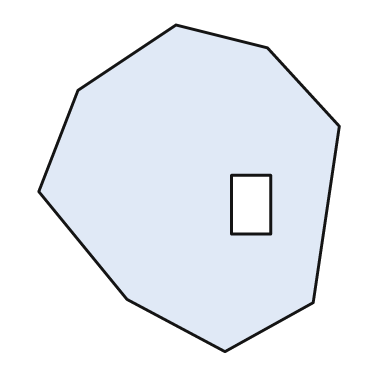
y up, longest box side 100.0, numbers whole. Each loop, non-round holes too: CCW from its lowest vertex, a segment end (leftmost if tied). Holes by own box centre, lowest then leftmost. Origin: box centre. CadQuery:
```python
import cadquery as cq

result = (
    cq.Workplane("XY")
    .moveTo(11.0, -50.0)
    .lineTo(38.0, -35.0)
    .lineTo(46.0, 19.0)
    .lineTo(24.0, 43.0)
    .lineTo(-4.0, 50.0)
    .lineTo(-34.0, 30.0)
    .lineTo(-46.0, -1.0)
    .lineTo(-19.0, -34.0)
    .close()
    .moveTo(13.0, -14.0)
    .lineTo(25.0, -14.0)
    .lineTo(25.0, 4.0)
    .lineTo(13.0, 4.0)
    .close()
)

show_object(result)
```